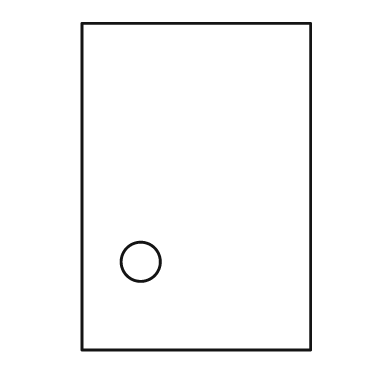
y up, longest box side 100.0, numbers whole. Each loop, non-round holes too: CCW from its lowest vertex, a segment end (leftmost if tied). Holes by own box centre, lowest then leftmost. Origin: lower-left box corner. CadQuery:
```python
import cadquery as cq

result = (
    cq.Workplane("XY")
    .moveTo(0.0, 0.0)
    .lineTo(70.0, 0.0)
    .lineTo(70.0, 100.0)
    .lineTo(0.0, 100.0)
    .close()
    .moveTo(18.0, 27.0)
    .circle(6.0)
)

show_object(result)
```